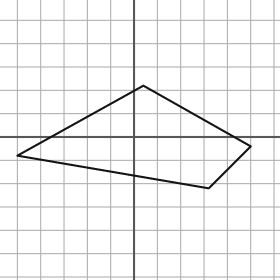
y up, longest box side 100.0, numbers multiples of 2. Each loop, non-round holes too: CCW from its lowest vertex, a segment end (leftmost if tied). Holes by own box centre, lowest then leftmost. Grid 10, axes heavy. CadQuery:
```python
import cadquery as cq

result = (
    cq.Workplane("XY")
    .moveTo(32.0, -22.0)
    .lineTo(50.0, -4.0)
    .lineTo(4.0, 22.0)
    .lineTo(-50.0, -8.0)
    .close()
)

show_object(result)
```